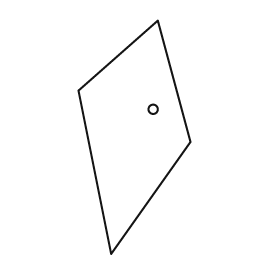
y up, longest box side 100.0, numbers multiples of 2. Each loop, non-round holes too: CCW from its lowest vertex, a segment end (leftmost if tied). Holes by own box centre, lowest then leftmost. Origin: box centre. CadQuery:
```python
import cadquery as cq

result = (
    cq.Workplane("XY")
    .moveTo(-10.0, -50.0)
    .lineTo(24.0, -2.0)
    .lineTo(10.0, 50.0)
    .lineTo(-24.0, 20.0)
    .close()
    .moveTo(8.0, 12.0)
    .circle(2.0)
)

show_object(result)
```